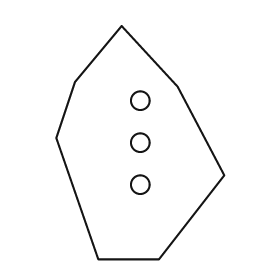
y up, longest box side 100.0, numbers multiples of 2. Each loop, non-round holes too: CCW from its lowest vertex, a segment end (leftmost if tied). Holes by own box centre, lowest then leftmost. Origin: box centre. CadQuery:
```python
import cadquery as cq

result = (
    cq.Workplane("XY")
    .moveTo(-18.0, -50.0)
    .lineTo(8.0, -50.0)
    .lineTo(36.0, -14.0)
    .lineTo(16.0, 24.0)
    .lineTo(-8.0, 50.0)
    .lineTo(-28.0, 26.0)
    .lineTo(-36.0, 2.0)
    .close()
    .moveTo(0.0, -18.0)
    .circle(4.0)
    .moveTo(0.0, 0.0)
    .circle(4.0)
    .moveTo(0.0, 18.0)
    .circle(4.0)
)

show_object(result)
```